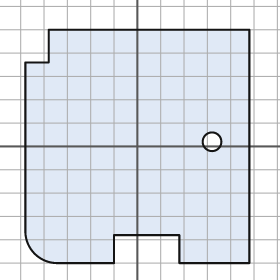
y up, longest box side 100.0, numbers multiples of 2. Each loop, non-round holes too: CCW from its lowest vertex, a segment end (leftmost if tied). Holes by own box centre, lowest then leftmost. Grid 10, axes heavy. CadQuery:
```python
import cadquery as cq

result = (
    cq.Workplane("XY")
    .moveTo(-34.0, -50.0)
    .lineTo(-10.0, -50.0)
    .lineTo(-10.0, -38.0)
    .lineTo(18.0, -38.0)
    .lineTo(18.0, -50.0)
    .lineTo(48.0, -50.0)
    .lineTo(48.0, 50.0)
    .lineTo(-38.0, 50.0)
    .lineTo(-38.0, 36.0)
    .lineTo(-48.0, 36.0)
    .lineTo(-48.0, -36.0)
    .threePointArc((-44.0, -46.0), (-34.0, -50.0))
    .close()
    .moveTo(32.0, 2.0)
    .circle(4.0)
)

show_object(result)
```